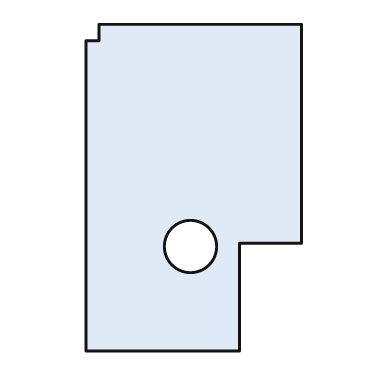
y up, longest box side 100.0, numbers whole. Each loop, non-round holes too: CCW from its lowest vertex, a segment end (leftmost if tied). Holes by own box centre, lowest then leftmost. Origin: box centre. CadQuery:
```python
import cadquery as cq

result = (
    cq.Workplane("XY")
    .moveTo(-33.0, -50.0)
    .lineTo(14.0, -50.0)
    .lineTo(14.0, -17.0)
    .lineTo(33.0, -17.0)
    .lineTo(33.0, 50.0)
    .lineTo(-29.0, 50.0)
    .lineTo(-29.0, 45.0)
    .lineTo(-33.0, 45.0)
    .close()
    .moveTo(-1.0, -18.0)
    .circle(8.0)
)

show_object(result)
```